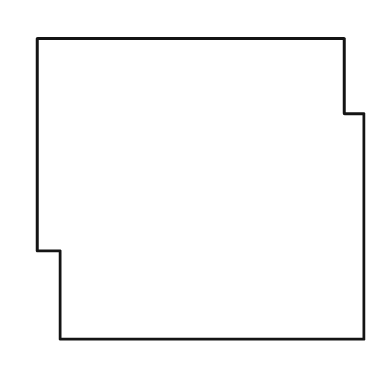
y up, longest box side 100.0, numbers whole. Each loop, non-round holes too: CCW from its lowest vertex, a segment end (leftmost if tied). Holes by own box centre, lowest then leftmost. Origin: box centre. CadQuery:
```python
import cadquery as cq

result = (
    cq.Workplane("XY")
    .moveTo(-43.0, -46.0)
    .lineTo(50.0, -46.0)
    .lineTo(50.0, 23.0)
    .lineTo(44.0, 23.0)
    .lineTo(44.0, 46.0)
    .lineTo(-50.0, 46.0)
    .lineTo(-50.0, -19.0)
    .lineTo(-43.0, -19.0)
    .close()
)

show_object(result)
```